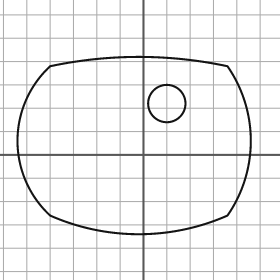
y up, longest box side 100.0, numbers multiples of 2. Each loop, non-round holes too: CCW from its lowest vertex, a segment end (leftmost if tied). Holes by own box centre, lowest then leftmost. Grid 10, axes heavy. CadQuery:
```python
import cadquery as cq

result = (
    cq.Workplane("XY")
    .moveTo(-40.0, -26.0)
    .threePointArc((-2.0, -34.0), (36.0, -26.0))
    .threePointArc((46.0, 6.0), (36.0, 38.0))
    .threePointArc((-2.0, 42.0), (-40.0, 38.0))
    .threePointArc((-54.0, 6.0), (-40.0, -26.0))
    .close()
    .moveTo(10.0, 22.0)
    .circle(8.0)
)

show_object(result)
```